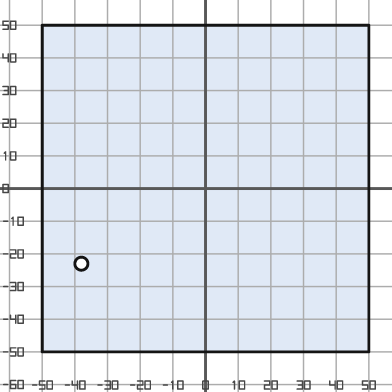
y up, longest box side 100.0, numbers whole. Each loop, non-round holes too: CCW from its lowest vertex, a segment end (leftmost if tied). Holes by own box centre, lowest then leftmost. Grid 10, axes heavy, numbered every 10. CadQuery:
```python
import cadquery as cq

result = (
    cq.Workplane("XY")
    .moveTo(-50.0, -50.0)
    .lineTo(50.0, -50.0)
    .lineTo(50.0, 50.0)
    .lineTo(-50.0, 50.0)
    .close()
    .moveTo(-38.0, -23.0)
    .circle(2.0)
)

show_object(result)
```